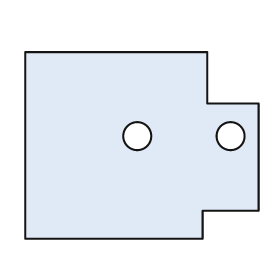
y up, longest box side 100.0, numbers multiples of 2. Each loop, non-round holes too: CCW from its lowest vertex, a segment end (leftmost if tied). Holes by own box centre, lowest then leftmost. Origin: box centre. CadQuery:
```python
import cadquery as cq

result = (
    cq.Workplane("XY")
    .moveTo(-50.0, -40.0)
    .lineTo(26.0, -40.0)
    .lineTo(26.0, -28.0)
    .lineTo(50.0, -28.0)
    .lineTo(50.0, 18.0)
    .lineTo(28.0, 18.0)
    .lineTo(28.0, 40.0)
    .lineTo(-50.0, 40.0)
    .close()
    .moveTo(-2.0, 4.0)
    .circle(6.0)
    .moveTo(38.0, 4.0)
    .circle(6.0)
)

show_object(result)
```